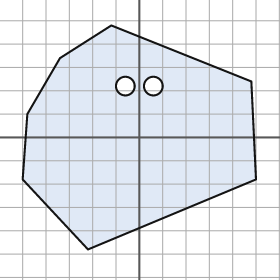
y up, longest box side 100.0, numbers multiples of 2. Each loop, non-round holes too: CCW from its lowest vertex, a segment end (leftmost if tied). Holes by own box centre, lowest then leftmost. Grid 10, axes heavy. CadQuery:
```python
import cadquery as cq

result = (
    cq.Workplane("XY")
    .moveTo(-22.0, -48.0)
    .lineTo(50.0, -18.0)
    .lineTo(48.0, 24.0)
    .lineTo(-12.0, 48.0)
    .lineTo(-34.0, 34.0)
    .lineTo(-48.0, 10.0)
    .lineTo(-50.0, -18.0)
    .close()
    .moveTo(-6.0, 22.0)
    .circle(4.0)
    .moveTo(6.0, 22.0)
    .circle(4.0)
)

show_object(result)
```